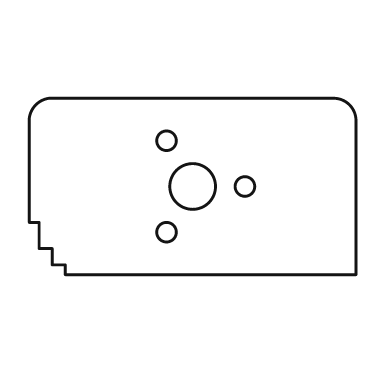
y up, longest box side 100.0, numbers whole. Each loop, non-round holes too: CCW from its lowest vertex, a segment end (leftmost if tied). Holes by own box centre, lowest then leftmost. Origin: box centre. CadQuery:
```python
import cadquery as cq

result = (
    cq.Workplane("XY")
    .moveTo(-39.0, -27.0)
    .lineTo(50.0, -27.0)
    .lineTo(50.0, 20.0)
    .threePointArc((48.0, 25.0), (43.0, 27.0))
    .lineTo(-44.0, 27.0)
    .threePointArc((-48.0, 25.0), (-50.0, 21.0))
    .lineTo(-50.0, -11.0)
    .lineTo(-47.0, -11.0)
    .lineTo(-47.0, -19.0)
    .lineTo(-43.0, -19.0)
    .lineTo(-43.0, -24.0)
    .lineTo(-39.0, -24.0)
    .close()
    .moveTo(-8.0, -14.0)
    .circle(3.0)
    .moveTo(0.0, 0.0)
    .circle(7.0)
    .moveTo(16.0, 0.0)
    .circle(3.0)
    .moveTo(-8.0, 14.0)
    .circle(3.0)
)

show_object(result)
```